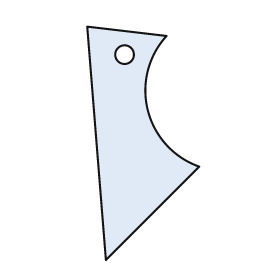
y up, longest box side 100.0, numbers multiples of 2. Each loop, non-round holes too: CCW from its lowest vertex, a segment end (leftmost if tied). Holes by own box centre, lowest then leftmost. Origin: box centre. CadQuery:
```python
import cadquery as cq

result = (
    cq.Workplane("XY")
    .moveTo(-16.0, -50.0)
    .lineTo(24.0, -10.0)
    .threePointArc((2.0, 14.0), (10.0, 46.0))
    .lineTo(-24.0, 50.0)
    .close()
    .moveTo(-8.0, 38.0)
    .circle(4.0)
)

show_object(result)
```